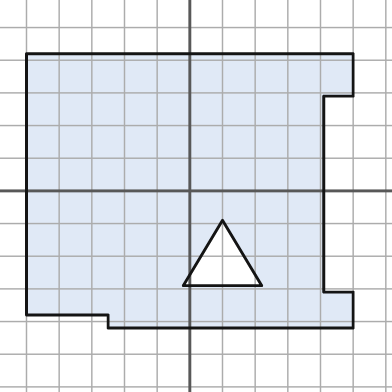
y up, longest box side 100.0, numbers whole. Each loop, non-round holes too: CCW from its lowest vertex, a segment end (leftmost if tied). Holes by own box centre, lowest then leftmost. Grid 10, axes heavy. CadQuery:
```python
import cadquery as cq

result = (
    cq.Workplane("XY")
    .moveTo(-25.0, -42.0)
    .lineTo(50.0, -42.0)
    .lineTo(50.0, -31.0)
    .lineTo(41.0, -31.0)
    .lineTo(41.0, 29.0)
    .lineTo(50.0, 29.0)
    .lineTo(50.0, 42.0)
    .lineTo(-50.0, 42.0)
    .lineTo(-50.0, -38.0)
    .lineTo(-25.0, -38.0)
    .close()
    .moveTo(-2.0, -29.0)
    .lineTo(22.0, -29.0)
    .lineTo(10.0, -9.0)
    .close()
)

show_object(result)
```